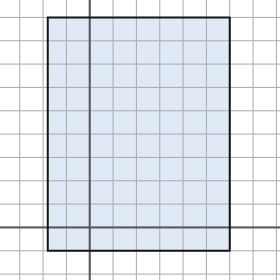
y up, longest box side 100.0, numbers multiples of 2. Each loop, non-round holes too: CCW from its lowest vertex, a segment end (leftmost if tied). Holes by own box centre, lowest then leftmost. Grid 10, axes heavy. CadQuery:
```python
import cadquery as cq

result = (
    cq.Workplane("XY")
    .moveTo(-18.0, -10.0)
    .lineTo(60.0, -10.0)
    .lineTo(60.0, 90.0)
    .lineTo(-18.0, 90.0)
    .close()
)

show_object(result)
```